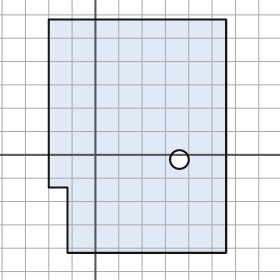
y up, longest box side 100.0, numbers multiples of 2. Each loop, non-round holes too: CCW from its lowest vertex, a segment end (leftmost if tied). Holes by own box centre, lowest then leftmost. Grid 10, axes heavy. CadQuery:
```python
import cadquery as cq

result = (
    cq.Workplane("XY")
    .moveTo(-12.0, -42.0)
    .lineTo(56.0, -42.0)
    .lineTo(56.0, 58.0)
    .lineTo(-20.0, 58.0)
    .lineTo(-20.0, -14.0)
    .lineTo(-12.0, -14.0)
    .close()
    .moveTo(36.0, -2.0)
    .circle(4.0)
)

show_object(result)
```